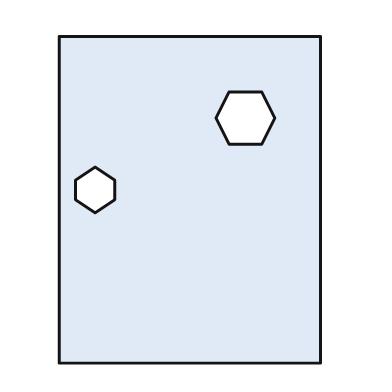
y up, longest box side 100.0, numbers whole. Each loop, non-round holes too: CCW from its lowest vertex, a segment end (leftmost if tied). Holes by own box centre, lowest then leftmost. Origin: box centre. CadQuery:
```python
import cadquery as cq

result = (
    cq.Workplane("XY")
    .moveTo(-40.0, -50.0)
    .lineTo(40.0, -50.0)
    .lineTo(40.0, 50.0)
    .lineTo(-40.0, 50.0)
    .close()
    .moveTo(-29.0, -4.0)
    .lineTo(-23.0, 0.0)
    .lineTo(-23.0, 6.0)
    .lineTo(-29.0, 10.0)
    .lineTo(-35.0, 6.0)
    .lineTo(-35.0, 0.0)
    .close()
    .moveTo(12.0, 17.0)
    .lineTo(22.0, 17.0)
    .lineTo(26.0, 25.0)
    .lineTo(22.0, 33.0)
    .lineTo(12.0, 33.0)
    .lineTo(8.0, 25.0)
    .close()
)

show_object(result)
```